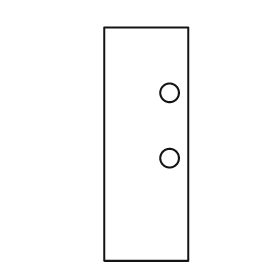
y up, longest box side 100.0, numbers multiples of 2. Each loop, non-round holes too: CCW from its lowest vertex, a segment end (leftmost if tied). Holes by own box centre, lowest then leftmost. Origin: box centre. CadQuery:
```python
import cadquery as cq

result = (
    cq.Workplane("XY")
    .moveTo(-18.0, -50.0)
    .lineTo(18.0, -50.0)
    .lineTo(18.0, 50.0)
    .lineTo(-18.0, 50.0)
    .close()
    .moveTo(10.0, -6.0)
    .circle(4.0)
    .moveTo(10.0, 22.0)
    .circle(4.0)
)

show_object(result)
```